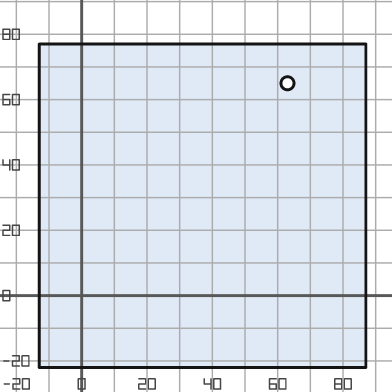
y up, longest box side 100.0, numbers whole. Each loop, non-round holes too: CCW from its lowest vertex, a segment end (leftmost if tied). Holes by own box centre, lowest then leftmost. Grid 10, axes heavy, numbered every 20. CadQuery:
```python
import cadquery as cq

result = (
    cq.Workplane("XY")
    .moveTo(-13.0, -22.0)
    .lineTo(87.0, -22.0)
    .lineTo(87.0, 77.0)
    .lineTo(-13.0, 77.0)
    .close()
    .moveTo(63.0, 65.0)
    .circle(2.0)
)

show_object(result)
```